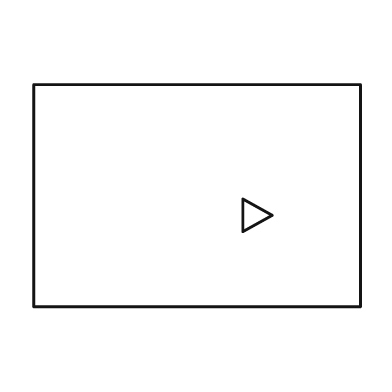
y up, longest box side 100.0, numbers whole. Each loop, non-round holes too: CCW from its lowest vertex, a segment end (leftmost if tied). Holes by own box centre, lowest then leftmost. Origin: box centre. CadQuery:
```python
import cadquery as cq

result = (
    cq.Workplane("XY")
    .moveTo(-50.0, -34.0)
    .lineTo(50.0, -34.0)
    .lineTo(50.0, 34.0)
    .lineTo(-50.0, 34.0)
    .close()
    .moveTo(14.0, -11.0)
    .lineTo(23.0, -6.0)
    .lineTo(14.0, -1.0)
    .close()
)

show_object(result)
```